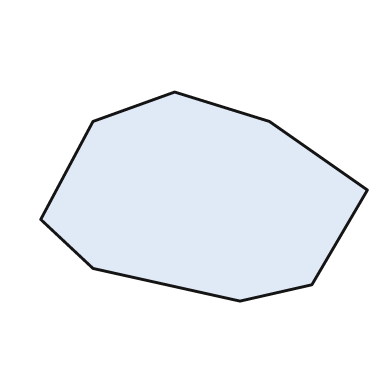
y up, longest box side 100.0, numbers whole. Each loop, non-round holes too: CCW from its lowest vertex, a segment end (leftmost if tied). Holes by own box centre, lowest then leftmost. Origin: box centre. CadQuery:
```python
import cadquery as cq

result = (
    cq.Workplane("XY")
    .moveTo(11.0, -32.0)
    .lineTo(33.0, -27.0)
    .lineTo(50.0, 2.0)
    .lineTo(20.0, 23.0)
    .lineTo(-9.0, 32.0)
    .lineTo(-34.0, 23.0)
    .lineTo(-50.0, -7.0)
    .lineTo(-34.0, -22.0)
    .close()
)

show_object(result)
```